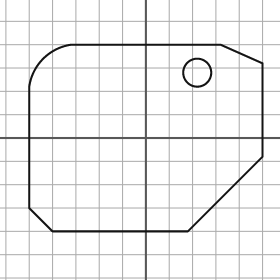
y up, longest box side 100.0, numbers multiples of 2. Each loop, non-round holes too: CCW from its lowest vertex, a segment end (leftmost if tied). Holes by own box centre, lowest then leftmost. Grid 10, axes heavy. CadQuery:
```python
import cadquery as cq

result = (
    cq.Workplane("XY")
    .moveTo(-40.0, -40.0)
    .lineTo(18.0, -40.0)
    .lineTo(50.0, -8.0)
    .lineTo(50.0, 32.0)
    .lineTo(32.0, 40.0)
    .lineTo(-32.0, 40.0)
    .threePointArc((-44.0, 34.0), (-50.0, 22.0))
    .lineTo(-50.0, -30.0)
    .close()
    .moveTo(22.0, 28.0)
    .circle(6.0)
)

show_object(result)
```